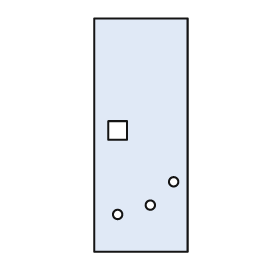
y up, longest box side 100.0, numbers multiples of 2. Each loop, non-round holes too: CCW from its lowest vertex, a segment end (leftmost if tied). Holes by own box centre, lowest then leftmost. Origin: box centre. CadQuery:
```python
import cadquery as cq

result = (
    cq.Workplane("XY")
    .moveTo(-20.0, -50.0)
    .lineTo(20.0, -50.0)
    .lineTo(20.0, 50.0)
    .lineTo(-20.0, 50.0)
    .close()
    .moveTo(-10.0, -34.0)
    .circle(2.0)
    .moveTo(4.0, -30.0)
    .circle(2.0)
    .moveTo(14.0, -20.0)
    .circle(2.0)
    .moveTo(-14.0, -2.0)
    .lineTo(-6.0, -2.0)
    .lineTo(-6.0, 6.0)
    .lineTo(-14.0, 6.0)
    .close()
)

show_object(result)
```